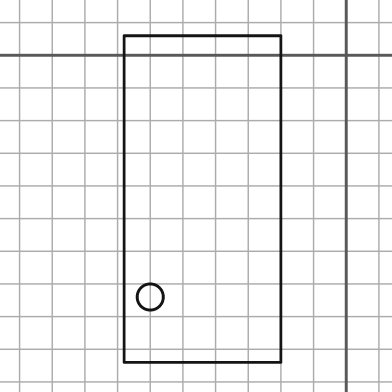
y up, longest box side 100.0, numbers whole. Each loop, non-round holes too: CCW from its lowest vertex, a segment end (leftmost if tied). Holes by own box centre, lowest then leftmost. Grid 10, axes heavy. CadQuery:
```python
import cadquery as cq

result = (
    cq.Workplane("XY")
    .moveTo(-68.0, -94.0)
    .lineTo(-20.0, -94.0)
    .lineTo(-20.0, 6.0)
    .lineTo(-68.0, 6.0)
    .close()
    .moveTo(-60.0, -74.0)
    .circle(4.0)
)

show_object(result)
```